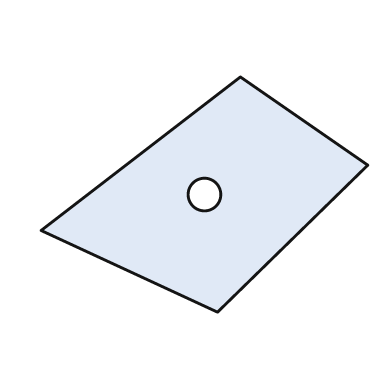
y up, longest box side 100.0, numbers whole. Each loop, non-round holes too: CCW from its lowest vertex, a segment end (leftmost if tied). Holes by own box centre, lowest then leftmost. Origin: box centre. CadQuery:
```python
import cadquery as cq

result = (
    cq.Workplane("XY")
    .moveTo(4.0, -36.0)
    .lineTo(50.0, 9.0)
    .lineTo(11.0, 36.0)
    .lineTo(-50.0, -11.0)
    .close()
    .moveTo(0.0, 0.0)
    .circle(5.0)
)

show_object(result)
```